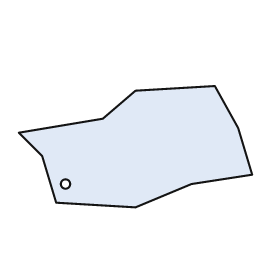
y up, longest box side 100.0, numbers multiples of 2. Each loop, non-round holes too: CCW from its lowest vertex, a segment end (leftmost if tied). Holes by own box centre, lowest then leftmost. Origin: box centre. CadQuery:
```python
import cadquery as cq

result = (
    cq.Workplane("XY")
    .moveTo(0.0, -26.0)
    .lineTo(24.0, -16.0)
    .lineTo(50.0, -12.0)
    .lineTo(44.0, 8.0)
    .lineTo(34.0, 26.0)
    .lineTo(0.0, 24.0)
    .lineTo(-14.0, 12.0)
    .lineTo(-50.0, 6.0)
    .lineTo(-40.0, -4.0)
    .lineTo(-34.0, -24.0)
    .close()
    .moveTo(-30.0, -16.0)
    .circle(2.0)
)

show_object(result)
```